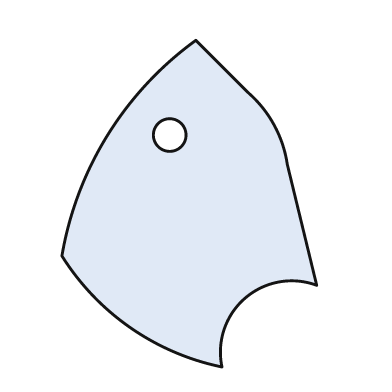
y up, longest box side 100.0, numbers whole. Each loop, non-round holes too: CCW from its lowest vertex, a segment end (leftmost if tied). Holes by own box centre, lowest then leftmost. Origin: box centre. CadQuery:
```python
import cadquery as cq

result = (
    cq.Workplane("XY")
    .moveTo(10.0, -50.0)
    .threePointArc((17.0, -29.0), (39.0, -25.0))
    .lineTo(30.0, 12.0)
    .threePointArc((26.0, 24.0), (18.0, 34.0))
    .lineTo(2.0, 50.0)
    .threePointArc((-25.0, 21.0), (-39.0, -16.0))
    .threePointArc((-18.0, -38.0), (10.0, -50.0))
    .close()
    .moveTo(-6.0, 21.0)
    .circle(5.0)
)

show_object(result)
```